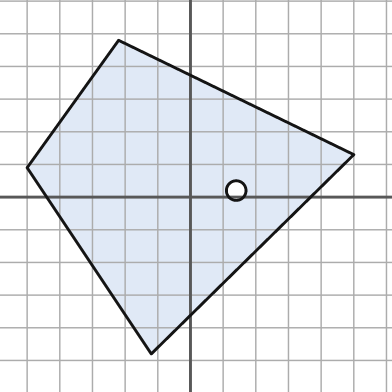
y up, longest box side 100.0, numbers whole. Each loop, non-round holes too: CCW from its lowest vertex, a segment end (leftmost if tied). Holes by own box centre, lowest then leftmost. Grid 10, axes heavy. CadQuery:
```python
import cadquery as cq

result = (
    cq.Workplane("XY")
    .moveTo(-12.0, -48.0)
    .lineTo(50.0, 13.0)
    .lineTo(-22.0, 48.0)
    .lineTo(-50.0, 9.0)
    .close()
    .moveTo(14.0, 2.0)
    .circle(3.0)
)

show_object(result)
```